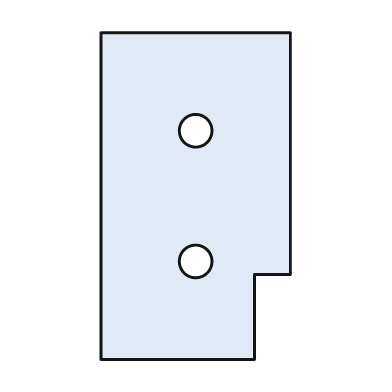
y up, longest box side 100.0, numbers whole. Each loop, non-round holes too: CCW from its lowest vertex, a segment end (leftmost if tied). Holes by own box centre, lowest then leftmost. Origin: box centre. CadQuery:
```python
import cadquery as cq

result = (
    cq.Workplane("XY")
    .moveTo(-29.0, -50.0)
    .lineTo(18.0, -50.0)
    .lineTo(18.0, -24.0)
    .lineTo(29.0, -24.0)
    .lineTo(29.0, 50.0)
    .lineTo(-29.0, 50.0)
    .close()
    .moveTo(0.0, -20.0)
    .circle(5.0)
    .moveTo(0.0, 20.0)
    .circle(5.0)
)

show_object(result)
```